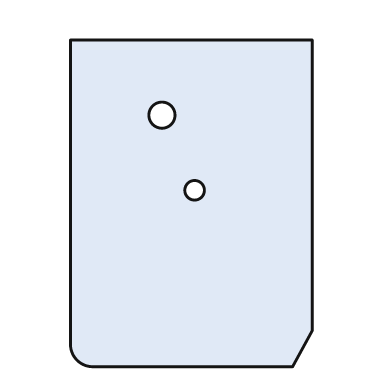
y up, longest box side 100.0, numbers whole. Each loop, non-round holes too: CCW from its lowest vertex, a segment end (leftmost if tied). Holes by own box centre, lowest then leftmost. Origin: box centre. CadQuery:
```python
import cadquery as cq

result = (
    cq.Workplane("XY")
    .moveTo(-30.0, -50.0)
    .lineTo(31.0, -50.0)
    .lineTo(37.0, -39.0)
    .lineTo(37.0, 50.0)
    .lineTo(-37.0, 50.0)
    .lineTo(-37.0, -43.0)
    .threePointArc((-35.0, -48.0), (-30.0, -50.0))
    .close()
    .moveTo(1.0, 4.0)
    .circle(3.0)
    .moveTo(-9.0, 27.0)
    .circle(4.0)
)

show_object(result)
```